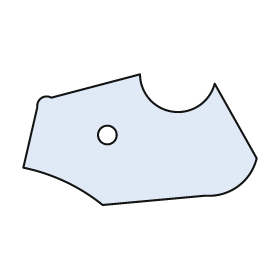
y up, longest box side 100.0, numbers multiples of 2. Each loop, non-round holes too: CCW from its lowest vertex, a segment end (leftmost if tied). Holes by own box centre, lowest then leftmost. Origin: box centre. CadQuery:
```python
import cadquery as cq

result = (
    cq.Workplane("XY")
    .moveTo(-16.0, -28.0)
    .lineTo(28.0, -24.0)
    .threePointArc((42.0, -20.0), (50.0, -8.0))
    .lineTo(32.0, 24.0)
    .threePointArc((14.0, 12.0), (0.0, 28.0))
    .lineTo(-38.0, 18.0)
    .threePointArc((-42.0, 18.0), (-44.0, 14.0))
    .lineTo(-50.0, -12.0)
    .threePointArc((-32.0, -18.0), (-16.0, -28.0))
    .close()
    .moveTo(-14.0, 2.0)
    .circle(4.0)
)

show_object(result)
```